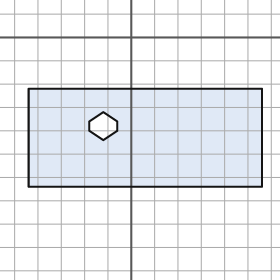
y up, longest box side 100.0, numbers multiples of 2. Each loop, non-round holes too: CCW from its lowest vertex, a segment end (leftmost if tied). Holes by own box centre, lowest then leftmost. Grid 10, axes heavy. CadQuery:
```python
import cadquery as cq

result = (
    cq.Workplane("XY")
    .moveTo(-44.0, -64.0)
    .lineTo(56.0, -64.0)
    .lineTo(56.0, -22.0)
    .lineTo(-44.0, -22.0)
    .close()
    .moveTo(-12.0, -44.0)
    .lineTo(-6.0, -40.0)
    .lineTo(-6.0, -36.0)
    .lineTo(-12.0, -32.0)
    .lineTo(-18.0, -36.0)
    .lineTo(-18.0, -40.0)
    .close()
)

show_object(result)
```